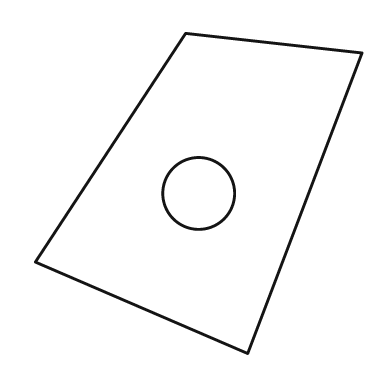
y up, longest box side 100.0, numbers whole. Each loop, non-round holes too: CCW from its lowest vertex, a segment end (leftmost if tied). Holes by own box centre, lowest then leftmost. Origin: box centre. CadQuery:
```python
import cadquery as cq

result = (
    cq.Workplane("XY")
    .moveTo(15.0, -49.0)
    .lineTo(50.0, 43.0)
    .lineTo(-4.0, 49.0)
    .lineTo(-50.0, -21.0)
    .close()
    .moveTo(0.0, 0.0)
    .circle(11.0)
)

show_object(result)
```